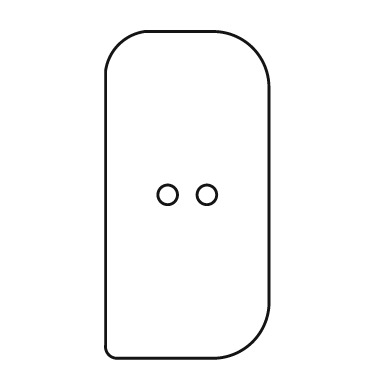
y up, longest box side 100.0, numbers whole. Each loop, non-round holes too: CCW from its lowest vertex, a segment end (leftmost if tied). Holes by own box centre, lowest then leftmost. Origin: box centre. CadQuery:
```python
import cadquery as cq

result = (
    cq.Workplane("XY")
    .moveTo(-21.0, -50.0)
    .lineTo(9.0, -50.0)
    .threePointArc((20.0, -45.0), (25.0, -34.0))
    .lineTo(25.0, 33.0)
    .threePointArc((20.0, 45.0), (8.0, 50.0))
    .lineTo(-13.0, 50.0)
    .threePointArc((-21.0, 46.0), (-25.0, 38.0))
    .lineTo(-25.0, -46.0)
    .threePointArc((-24.0, -49.0), (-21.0, -50.0))
    .close()
    .moveTo(-6.0, 0.0)
    .circle(3.0)
    .moveTo(6.0, 0.0)
    .circle(3.0)
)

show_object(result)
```